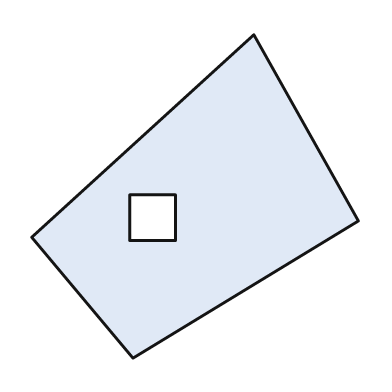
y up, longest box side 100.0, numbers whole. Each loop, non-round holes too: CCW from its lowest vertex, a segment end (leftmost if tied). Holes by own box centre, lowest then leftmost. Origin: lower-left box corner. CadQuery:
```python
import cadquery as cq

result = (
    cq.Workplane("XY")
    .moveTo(31.0, 0.0)
    .lineTo(100.0, 42.0)
    .lineTo(68.0, 99.0)
    .lineTo(0.0, 37.0)
    .close()
    .moveTo(30.0, 36.0)
    .lineTo(44.0, 36.0)
    .lineTo(44.0, 50.0)
    .lineTo(30.0, 50.0)
    .close()
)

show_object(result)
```